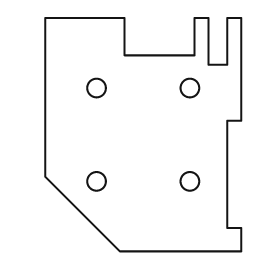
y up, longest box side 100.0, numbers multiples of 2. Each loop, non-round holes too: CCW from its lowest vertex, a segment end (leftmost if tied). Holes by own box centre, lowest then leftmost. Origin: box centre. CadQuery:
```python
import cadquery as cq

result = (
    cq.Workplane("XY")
    .moveTo(-10.0, -50.0)
    .lineTo(42.0, -50.0)
    .lineTo(42.0, -40.0)
    .lineTo(36.0, -40.0)
    .lineTo(36.0, 6.0)
    .lineTo(42.0, 6.0)
    .lineTo(42.0, 50.0)
    .lineTo(36.0, 50.0)
    .lineTo(36.0, 30.0)
    .lineTo(28.0, 30.0)
    .lineTo(28.0, 50.0)
    .lineTo(22.0, 50.0)
    .lineTo(22.0, 34.0)
    .lineTo(-8.0, 34.0)
    .lineTo(-8.0, 50.0)
    .lineTo(-42.0, 50.0)
    .lineTo(-42.0, -18.0)
    .close()
    .moveTo(-20.0, -20.0)
    .circle(4.0)
    .moveTo(20.0, -20.0)
    .circle(4.0)
    .moveTo(-20.0, 20.0)
    .circle(4.0)
    .moveTo(20.0, 20.0)
    .circle(4.0)
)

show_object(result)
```